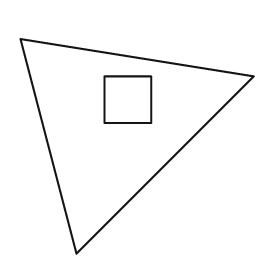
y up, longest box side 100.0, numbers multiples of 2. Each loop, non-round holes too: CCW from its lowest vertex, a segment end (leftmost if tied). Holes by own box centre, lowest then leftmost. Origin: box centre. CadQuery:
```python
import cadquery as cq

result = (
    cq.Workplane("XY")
    .moveTo(-26.0, -46.0)
    .lineTo(50.0, 30.0)
    .lineTo(-50.0, 46.0)
    .close()
    .moveTo(-14.0, 10.0)
    .lineTo(6.0, 10.0)
    .lineTo(6.0, 30.0)
    .lineTo(-14.0, 30.0)
    .close()
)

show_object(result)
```